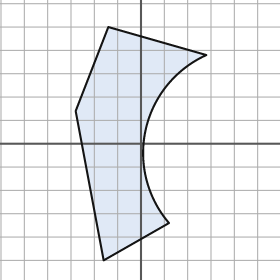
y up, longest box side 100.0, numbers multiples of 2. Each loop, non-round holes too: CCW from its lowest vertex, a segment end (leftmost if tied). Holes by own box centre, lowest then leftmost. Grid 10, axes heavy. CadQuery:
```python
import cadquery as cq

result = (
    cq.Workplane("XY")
    .moveTo(-16.0, -50.0)
    .lineTo(12.0, -34.0)
    .threePointArc((2.0, 6.0), (28.0, 38.0))
    .lineTo(-14.0, 50.0)
    .lineTo(-28.0, 14.0)
    .close()
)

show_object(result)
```